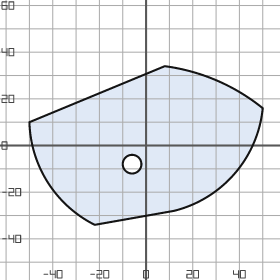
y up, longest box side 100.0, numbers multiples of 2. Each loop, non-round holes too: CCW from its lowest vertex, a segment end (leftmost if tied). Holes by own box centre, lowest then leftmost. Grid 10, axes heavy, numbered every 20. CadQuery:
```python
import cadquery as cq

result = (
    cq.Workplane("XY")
    .moveTo(-22.0, -34.0)
    .lineTo(12.0, -28.0)
    .threePointArc((38.0, -12.0), (50.0, 16.0))
    .threePointArc((30.0, 28.0), (8.0, 34.0))
    .lineTo(-50.0, 10.0)
    .threePointArc((-42.0, -16.0), (-22.0, -34.0))
    .close()
    .moveTo(-6.0, -8.0)
    .circle(4.0)
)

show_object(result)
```